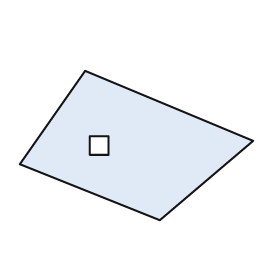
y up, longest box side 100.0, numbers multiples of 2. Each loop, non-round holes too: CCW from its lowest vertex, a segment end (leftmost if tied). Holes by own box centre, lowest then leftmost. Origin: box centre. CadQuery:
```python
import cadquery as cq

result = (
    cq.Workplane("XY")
    .moveTo(10.0, -32.0)
    .lineTo(50.0, 2.0)
    .lineTo(-22.0, 32.0)
    .lineTo(-50.0, -8.0)
    .close()
    .moveTo(-20.0, -4.0)
    .lineTo(-12.0, -4.0)
    .lineTo(-12.0, 4.0)
    .lineTo(-20.0, 4.0)
    .close()
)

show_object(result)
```